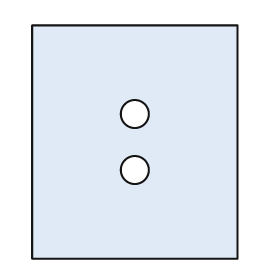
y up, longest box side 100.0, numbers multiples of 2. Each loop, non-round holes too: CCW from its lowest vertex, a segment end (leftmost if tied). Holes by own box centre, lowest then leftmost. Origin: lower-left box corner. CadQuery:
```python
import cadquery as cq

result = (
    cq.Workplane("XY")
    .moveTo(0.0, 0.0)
    .lineTo(88.0, 0.0)
    .lineTo(88.0, 100.0)
    .lineTo(0.0, 100.0)
    .close()
    .moveTo(44.0, 38.0)
    .circle(6.0)
    .moveTo(44.0, 62.0)
    .circle(6.0)
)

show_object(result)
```